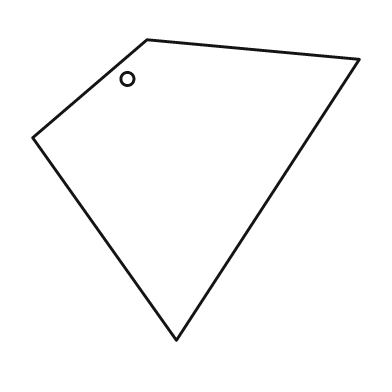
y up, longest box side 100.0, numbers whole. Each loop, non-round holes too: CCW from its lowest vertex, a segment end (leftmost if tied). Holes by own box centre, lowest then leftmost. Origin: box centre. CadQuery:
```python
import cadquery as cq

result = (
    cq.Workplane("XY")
    .moveTo(-6.0, -46.0)
    .lineTo(50.0, 40.0)
    .lineTo(-15.0, 46.0)
    .lineTo(-50.0, 16.0)
    .close()
    .moveTo(-21.0, 34.0)
    .circle(2.0)
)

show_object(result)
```